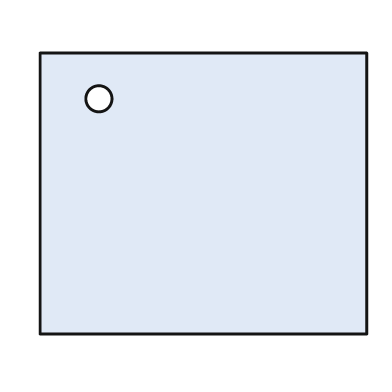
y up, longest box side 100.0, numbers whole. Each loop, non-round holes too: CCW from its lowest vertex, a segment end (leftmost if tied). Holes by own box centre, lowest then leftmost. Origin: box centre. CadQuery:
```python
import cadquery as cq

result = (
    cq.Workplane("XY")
    .moveTo(-50.0, -43.0)
    .lineTo(50.0, -43.0)
    .lineTo(50.0, 43.0)
    .lineTo(-50.0, 43.0)
    .close()
    .moveTo(-32.0, 29.0)
    .circle(4.0)
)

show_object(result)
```